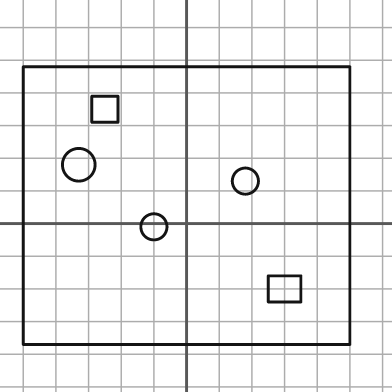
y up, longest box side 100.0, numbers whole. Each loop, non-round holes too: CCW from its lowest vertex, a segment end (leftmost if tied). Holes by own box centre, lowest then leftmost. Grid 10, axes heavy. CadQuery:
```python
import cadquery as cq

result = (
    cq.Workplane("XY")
    .moveTo(-50.0, -37.0)
    .lineTo(50.0, -37.0)
    .lineTo(50.0, 48.0)
    .lineTo(-50.0, 48.0)
    .close()
    .moveTo(25.0, -24.0)
    .lineTo(35.0, -24.0)
    .lineTo(35.0, -16.0)
    .lineTo(25.0, -16.0)
    .close()
    .moveTo(-10.0, -1.0)
    .circle(4.0)
    .moveTo(18.0, 13.0)
    .circle(4.0)
    .moveTo(-33.0, 18.0)
    .circle(5.0)
    .moveTo(-29.0, 31.0)
    .lineTo(-21.0, 31.0)
    .lineTo(-21.0, 39.0)
    .lineTo(-29.0, 39.0)
    .close()
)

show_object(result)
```